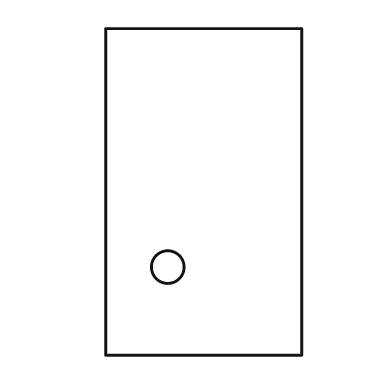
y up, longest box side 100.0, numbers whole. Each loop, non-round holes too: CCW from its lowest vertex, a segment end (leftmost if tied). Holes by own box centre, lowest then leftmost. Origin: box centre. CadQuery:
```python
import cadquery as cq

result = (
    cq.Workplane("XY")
    .moveTo(-30.0, -50.0)
    .lineTo(30.0, -50.0)
    .lineTo(30.0, 50.0)
    .lineTo(-30.0, 50.0)
    .close()
    .moveTo(-11.0, -23.0)
    .circle(5.0)
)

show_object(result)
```